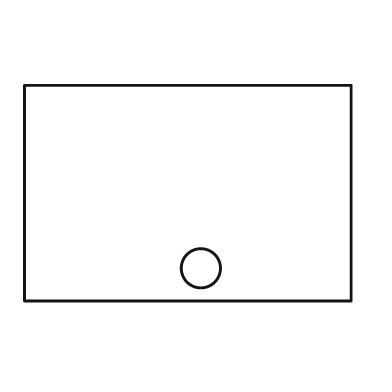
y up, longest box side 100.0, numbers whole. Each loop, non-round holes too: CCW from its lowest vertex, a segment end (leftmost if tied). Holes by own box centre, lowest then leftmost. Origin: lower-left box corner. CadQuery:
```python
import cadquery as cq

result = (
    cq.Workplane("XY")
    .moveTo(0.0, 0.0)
    .lineTo(100.0, 0.0)
    .lineTo(100.0, 66.0)
    .lineTo(0.0, 66.0)
    .close()
    .moveTo(54.0, 10.0)
    .circle(6.0)
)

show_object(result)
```